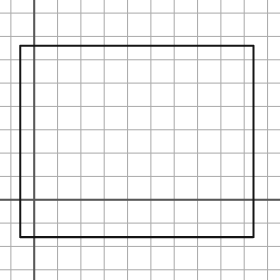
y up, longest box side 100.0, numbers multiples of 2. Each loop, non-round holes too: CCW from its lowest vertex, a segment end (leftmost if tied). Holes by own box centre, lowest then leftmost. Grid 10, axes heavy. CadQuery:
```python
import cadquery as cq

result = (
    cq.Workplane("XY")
    .moveTo(-6.0, -16.0)
    .lineTo(94.0, -16.0)
    .lineTo(94.0, 66.0)
    .lineTo(-6.0, 66.0)
    .close()
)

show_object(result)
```